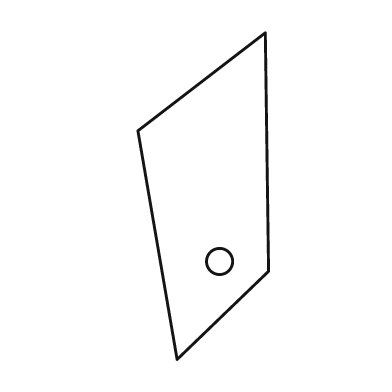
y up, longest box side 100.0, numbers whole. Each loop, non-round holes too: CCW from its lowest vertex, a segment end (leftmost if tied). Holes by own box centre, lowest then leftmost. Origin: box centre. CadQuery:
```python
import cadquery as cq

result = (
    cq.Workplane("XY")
    .moveTo(-8.0, -50.0)
    .lineTo(20.0, -23.0)
    .lineTo(19.0, 50.0)
    .lineTo(-20.0, 20.0)
    .close()
    .moveTo(5.0, -20.0)
    .circle(4.0)
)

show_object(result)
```